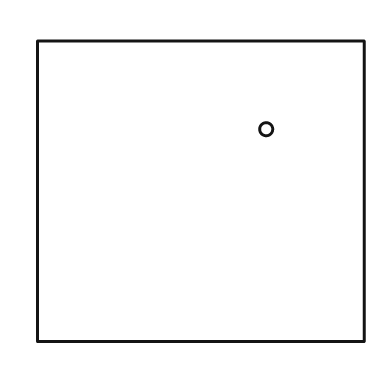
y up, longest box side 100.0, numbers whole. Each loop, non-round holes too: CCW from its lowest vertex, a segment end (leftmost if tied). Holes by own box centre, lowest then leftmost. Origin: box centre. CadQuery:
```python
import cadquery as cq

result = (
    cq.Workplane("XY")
    .moveTo(-50.0, -46.0)
    .lineTo(50.0, -46.0)
    .lineTo(50.0, 46.0)
    .lineTo(-50.0, 46.0)
    .close()
    .moveTo(20.0, 19.0)
    .circle(2.0)
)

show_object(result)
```